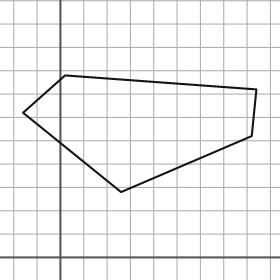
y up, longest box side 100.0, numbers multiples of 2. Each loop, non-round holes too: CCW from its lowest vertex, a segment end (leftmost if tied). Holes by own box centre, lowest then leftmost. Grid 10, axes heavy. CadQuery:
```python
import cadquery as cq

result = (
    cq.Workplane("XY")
    .moveTo(26.0, 28.0)
    .lineTo(82.0, 52.0)
    .lineTo(84.0, 72.0)
    .lineTo(2.0, 78.0)
    .lineTo(-16.0, 62.0)
    .close()
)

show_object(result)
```